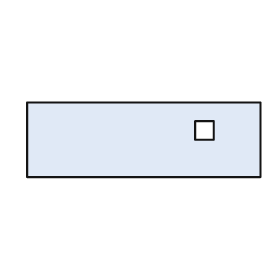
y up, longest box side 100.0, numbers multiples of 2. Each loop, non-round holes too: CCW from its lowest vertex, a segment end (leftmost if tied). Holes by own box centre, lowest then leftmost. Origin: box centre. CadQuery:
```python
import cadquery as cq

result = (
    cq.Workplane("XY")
    .moveTo(-50.0, -16.0)
    .lineTo(50.0, -16.0)
    .lineTo(50.0, 16.0)
    .lineTo(-50.0, 16.0)
    .close()
    .moveTo(22.0, 0.0)
    .lineTo(30.0, 0.0)
    .lineTo(30.0, 8.0)
    .lineTo(22.0, 8.0)
    .close()
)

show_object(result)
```